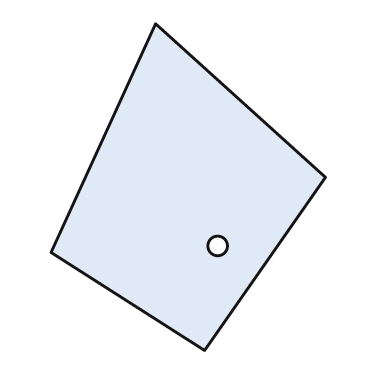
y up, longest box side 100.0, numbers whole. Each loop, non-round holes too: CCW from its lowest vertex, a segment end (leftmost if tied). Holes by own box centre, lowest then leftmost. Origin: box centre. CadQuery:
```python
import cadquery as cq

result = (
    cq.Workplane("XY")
    .moveTo(5.0, -50.0)
    .lineTo(42.0, 3.0)
    .lineTo(-10.0, 50.0)
    .lineTo(-42.0, -20.0)
    .close()
    .moveTo(9.0, -18.0)
    .circle(3.0)
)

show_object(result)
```